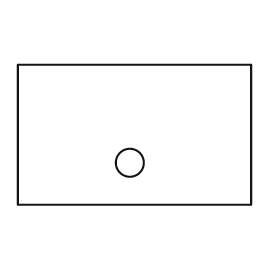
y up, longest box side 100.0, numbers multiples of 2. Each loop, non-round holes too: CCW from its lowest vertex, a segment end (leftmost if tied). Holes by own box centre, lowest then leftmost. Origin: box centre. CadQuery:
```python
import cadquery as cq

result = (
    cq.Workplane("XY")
    .moveTo(-50.0, -30.0)
    .lineTo(50.0, -30.0)
    .lineTo(50.0, 30.0)
    .lineTo(-50.0, 30.0)
    .close()
    .moveTo(-2.0, -12.0)
    .circle(6.0)
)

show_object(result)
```